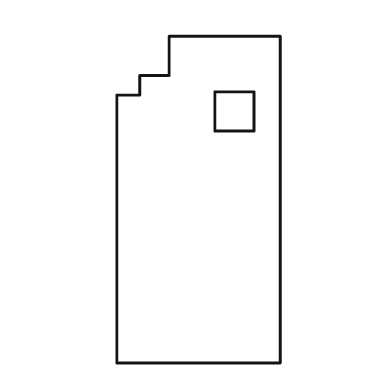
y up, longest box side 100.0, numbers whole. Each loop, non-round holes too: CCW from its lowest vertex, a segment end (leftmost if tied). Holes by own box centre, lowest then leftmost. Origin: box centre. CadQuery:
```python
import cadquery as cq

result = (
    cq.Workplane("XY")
    .moveTo(-25.0, -50.0)
    .lineTo(25.0, -50.0)
    .lineTo(25.0, 50.0)
    .lineTo(-9.0, 50.0)
    .lineTo(-9.0, 38.0)
    .lineTo(-18.0, 38.0)
    .lineTo(-18.0, 32.0)
    .lineTo(-25.0, 32.0)
    .close()
    .moveTo(5.0, 21.0)
    .lineTo(17.0, 21.0)
    .lineTo(17.0, 33.0)
    .lineTo(5.0, 33.0)
    .close()
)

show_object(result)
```